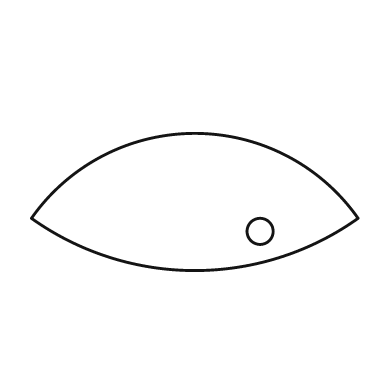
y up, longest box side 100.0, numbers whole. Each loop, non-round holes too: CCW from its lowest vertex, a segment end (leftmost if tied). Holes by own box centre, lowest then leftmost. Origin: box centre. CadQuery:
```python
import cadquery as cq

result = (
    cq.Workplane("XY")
    .moveTo(-50.0, -5.0)
    .threePointArc((0.0, -21.0), (50.0, -5.0))
    .threePointArc((0.0, 21.0), (-50.0, -5.0))
    .close()
    .moveTo(20.0, -9.0)
    .circle(4.0)
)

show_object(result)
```